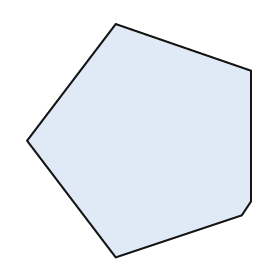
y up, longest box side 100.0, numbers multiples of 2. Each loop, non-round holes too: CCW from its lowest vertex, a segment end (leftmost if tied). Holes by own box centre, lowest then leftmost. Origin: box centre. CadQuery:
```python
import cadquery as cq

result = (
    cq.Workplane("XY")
    .moveTo(-10.0, -50.0)
    .lineTo(44.0, -32.0)
    .lineTo(48.0, -26.0)
    .lineTo(48.0, 30.0)
    .lineTo(-10.0, 50.0)
    .lineTo(-48.0, 0.0)
    .close()
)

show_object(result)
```